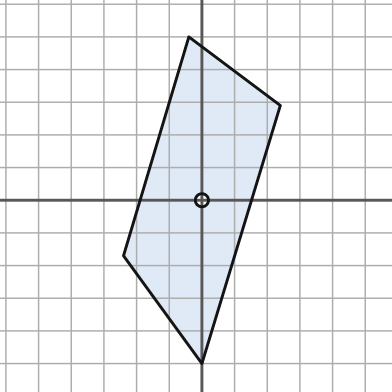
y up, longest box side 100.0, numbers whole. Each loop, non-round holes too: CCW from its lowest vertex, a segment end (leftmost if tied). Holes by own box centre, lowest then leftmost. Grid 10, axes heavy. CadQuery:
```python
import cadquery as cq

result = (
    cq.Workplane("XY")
    .moveTo(0.0, -50.0)
    .lineTo(24.0, 29.0)
    .lineTo(-4.0, 50.0)
    .lineTo(-24.0, -17.0)
    .close()
    .moveTo(0.0, 0.0)
    .circle(2.0)
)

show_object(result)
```